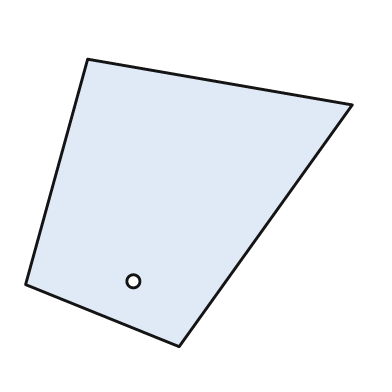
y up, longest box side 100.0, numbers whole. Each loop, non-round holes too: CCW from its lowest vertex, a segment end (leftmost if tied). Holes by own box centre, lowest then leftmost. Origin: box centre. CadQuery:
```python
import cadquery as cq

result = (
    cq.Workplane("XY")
    .moveTo(-3.0, -44.0)
    .lineTo(50.0, 30.0)
    .lineTo(-31.0, 44.0)
    .lineTo(-50.0, -25.0)
    .close()
    .moveTo(-17.0, -24.0)
    .circle(2.0)
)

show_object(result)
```